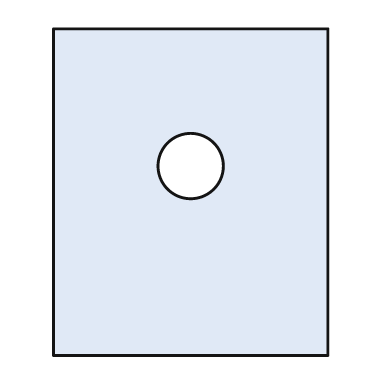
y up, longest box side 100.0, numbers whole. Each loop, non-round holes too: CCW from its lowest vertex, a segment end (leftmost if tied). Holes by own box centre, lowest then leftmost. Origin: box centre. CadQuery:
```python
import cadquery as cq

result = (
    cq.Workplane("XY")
    .moveTo(-42.0, -50.0)
    .lineTo(42.0, -50.0)
    .lineTo(42.0, 50.0)
    .lineTo(-42.0, 50.0)
    .close()
    .moveTo(0.0, 8.0)
    .circle(10.0)
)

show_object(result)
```